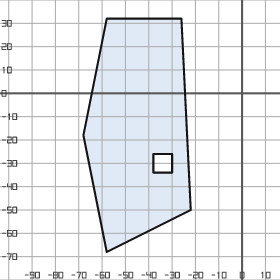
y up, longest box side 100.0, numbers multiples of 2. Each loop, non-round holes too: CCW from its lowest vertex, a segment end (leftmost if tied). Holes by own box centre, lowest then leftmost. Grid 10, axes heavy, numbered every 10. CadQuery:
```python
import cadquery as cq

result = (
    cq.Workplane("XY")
    .moveTo(-58.0, -68.0)
    .lineTo(-22.0, -50.0)
    .lineTo(-26.0, 32.0)
    .lineTo(-58.0, 32.0)
    .lineTo(-68.0, -18.0)
    .close()
    .moveTo(-38.0, -34.0)
    .lineTo(-30.0, -34.0)
    .lineTo(-30.0, -26.0)
    .lineTo(-38.0, -26.0)
    .close()
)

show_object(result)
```